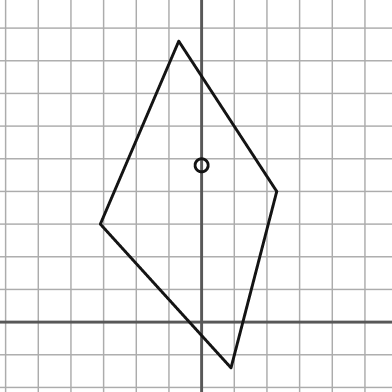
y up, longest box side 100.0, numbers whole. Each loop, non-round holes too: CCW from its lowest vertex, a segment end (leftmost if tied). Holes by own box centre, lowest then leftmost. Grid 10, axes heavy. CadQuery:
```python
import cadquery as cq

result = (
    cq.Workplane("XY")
    .moveTo(9.0, -14.0)
    .lineTo(23.0, 40.0)
    .lineTo(-7.0, 86.0)
    .lineTo(-31.0, 30.0)
    .close()
    .moveTo(0.0, 48.0)
    .circle(2.0)
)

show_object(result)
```